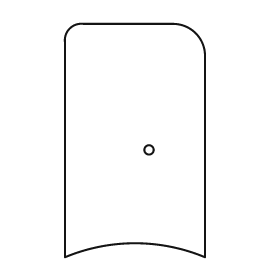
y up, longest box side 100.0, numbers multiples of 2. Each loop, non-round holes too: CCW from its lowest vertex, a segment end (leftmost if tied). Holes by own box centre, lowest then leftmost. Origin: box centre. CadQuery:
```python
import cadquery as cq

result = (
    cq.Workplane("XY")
    .moveTo(-30.0, -50.0)
    .threePointArc((0.0, -44.0), (30.0, -50.0))
    .lineTo(30.0, 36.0)
    .threePointArc((26.0, 46.0), (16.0, 50.0))
    .lineTo(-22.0, 50.0)
    .threePointArc((-28.0, 48.0), (-30.0, 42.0))
    .close()
    .moveTo(6.0, -4.0)
    .circle(2.0)
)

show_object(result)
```